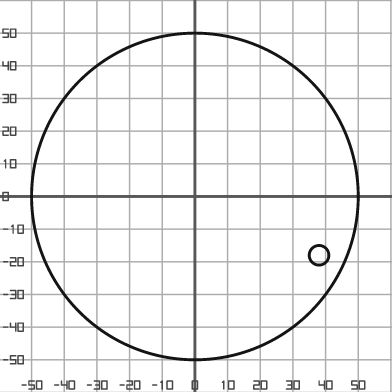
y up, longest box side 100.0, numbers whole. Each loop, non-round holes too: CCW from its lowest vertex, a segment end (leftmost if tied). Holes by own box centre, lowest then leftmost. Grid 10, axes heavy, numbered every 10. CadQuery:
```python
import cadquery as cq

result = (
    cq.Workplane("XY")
    .moveTo(0.0, 0.0)
    .circle(50.0)
    .moveTo(38.0, -18.0)
    .circle(3.0)
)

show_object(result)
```